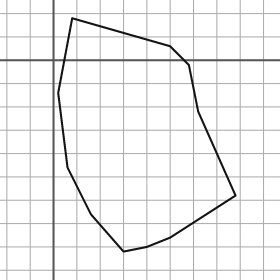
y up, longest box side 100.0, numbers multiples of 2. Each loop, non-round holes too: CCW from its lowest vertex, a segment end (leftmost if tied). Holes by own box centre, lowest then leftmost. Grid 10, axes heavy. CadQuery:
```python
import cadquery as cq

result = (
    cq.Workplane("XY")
    .moveTo(30.0, -82.0)
    .lineTo(40.0, -80.0)
    .lineTo(50.0, -76.0)
    .lineTo(78.0, -58.0)
    .lineTo(62.0, -22.0)
    .lineTo(58.0, -2.0)
    .lineTo(50.0, 6.0)
    .lineTo(8.0, 18.0)
    .lineTo(2.0, -14.0)
    .lineTo(6.0, -46.0)
    .lineTo(16.0, -66.0)
    .close()
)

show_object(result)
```